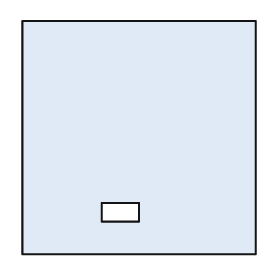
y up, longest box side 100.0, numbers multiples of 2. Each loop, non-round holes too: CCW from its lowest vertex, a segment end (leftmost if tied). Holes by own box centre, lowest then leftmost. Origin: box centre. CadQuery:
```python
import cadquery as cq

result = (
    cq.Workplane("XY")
    .moveTo(-50.0, -50.0)
    .lineTo(50.0, -50.0)
    .lineTo(50.0, 50.0)
    .lineTo(-50.0, 50.0)
    .close()
    .moveTo(-16.0, -36.0)
    .lineTo(0.0, -36.0)
    .lineTo(0.0, -28.0)
    .lineTo(-16.0, -28.0)
    .close()
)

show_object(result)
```